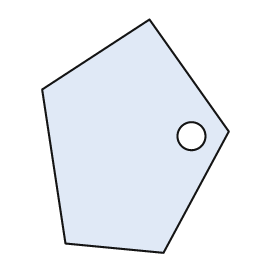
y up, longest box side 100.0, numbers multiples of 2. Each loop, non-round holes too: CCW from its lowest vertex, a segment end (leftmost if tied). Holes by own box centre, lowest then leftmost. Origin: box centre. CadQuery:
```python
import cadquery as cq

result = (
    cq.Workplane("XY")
    .moveTo(12.0, -50.0)
    .lineTo(40.0, 2.0)
    .lineTo(6.0, 50.0)
    .lineTo(-40.0, 20.0)
    .lineTo(-30.0, -46.0)
    .close()
    .moveTo(24.0, 0.0)
    .circle(6.0)
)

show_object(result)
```